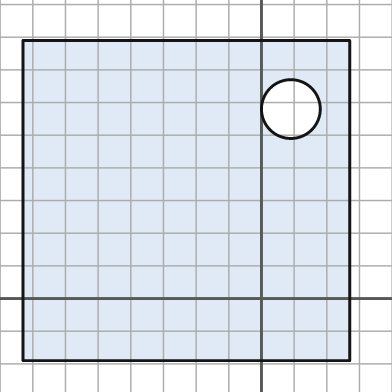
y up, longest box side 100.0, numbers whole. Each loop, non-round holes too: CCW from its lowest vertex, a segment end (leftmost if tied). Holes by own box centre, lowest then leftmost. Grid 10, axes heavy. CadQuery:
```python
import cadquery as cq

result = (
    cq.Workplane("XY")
    .moveTo(-73.0, -19.0)
    .lineTo(27.0, -19.0)
    .lineTo(27.0, 79.0)
    .lineTo(-73.0, 79.0)
    .close()
    .moveTo(9.0, 58.0)
    .circle(9.0)
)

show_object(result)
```